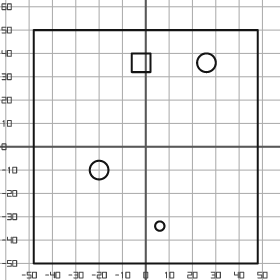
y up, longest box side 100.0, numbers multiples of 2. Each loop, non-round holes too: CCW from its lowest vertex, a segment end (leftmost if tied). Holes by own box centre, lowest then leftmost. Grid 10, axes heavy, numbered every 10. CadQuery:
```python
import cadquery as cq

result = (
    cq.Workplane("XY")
    .moveTo(-48.0, -50.0)
    .lineTo(48.0, -50.0)
    .lineTo(48.0, 50.0)
    .lineTo(-48.0, 50.0)
    .close()
    .moveTo(6.0, -34.0)
    .circle(2.0)
    .moveTo(-20.0, -10.0)
    .circle(4.0)
    .moveTo(-6.0, 32.0)
    .lineTo(2.0, 32.0)
    .lineTo(2.0, 40.0)
    .lineTo(-6.0, 40.0)
    .close()
    .moveTo(26.0, 36.0)
    .circle(4.0)
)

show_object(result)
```